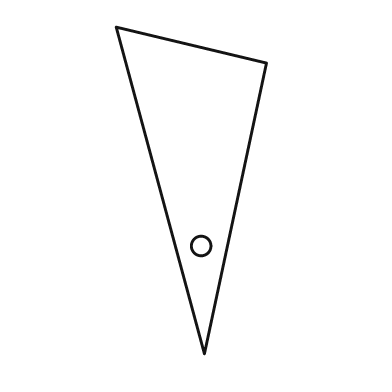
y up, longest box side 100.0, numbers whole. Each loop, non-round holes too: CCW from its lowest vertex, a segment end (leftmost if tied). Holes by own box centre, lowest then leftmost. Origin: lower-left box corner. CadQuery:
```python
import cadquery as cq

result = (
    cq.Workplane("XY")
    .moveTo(27.0, 0.0)
    .lineTo(46.0, 89.0)
    .lineTo(0.0, 100.0)
    .close()
    .moveTo(26.0, 33.0)
    .circle(3.0)
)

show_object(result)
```